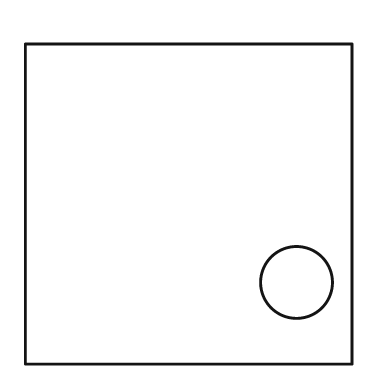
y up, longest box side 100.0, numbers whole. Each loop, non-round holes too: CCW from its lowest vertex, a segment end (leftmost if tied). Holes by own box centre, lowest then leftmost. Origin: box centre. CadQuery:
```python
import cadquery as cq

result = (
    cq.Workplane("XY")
    .moveTo(-50.0, -49.0)
    .lineTo(50.0, -49.0)
    .lineTo(50.0, 49.0)
    .lineTo(-50.0, 49.0)
    .close()
    .moveTo(33.0, -24.0)
    .circle(11.0)
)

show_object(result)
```